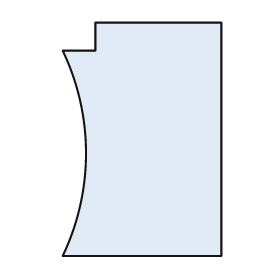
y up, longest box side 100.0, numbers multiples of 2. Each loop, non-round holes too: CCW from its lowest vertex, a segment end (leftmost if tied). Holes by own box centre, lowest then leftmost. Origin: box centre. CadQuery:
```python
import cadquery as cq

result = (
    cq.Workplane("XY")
    .moveTo(-34.0, -50.0)
    .lineTo(34.0, -50.0)
    .lineTo(34.0, 50.0)
    .lineTo(-20.0, 50.0)
    .lineTo(-20.0, 38.0)
    .lineTo(-34.0, 38.0)
    .threePointArc((-24.0, -6.0), (-34.0, -50.0))
    .close()
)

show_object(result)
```